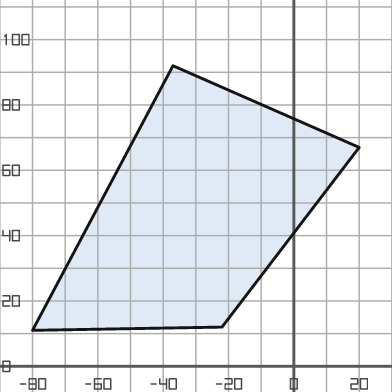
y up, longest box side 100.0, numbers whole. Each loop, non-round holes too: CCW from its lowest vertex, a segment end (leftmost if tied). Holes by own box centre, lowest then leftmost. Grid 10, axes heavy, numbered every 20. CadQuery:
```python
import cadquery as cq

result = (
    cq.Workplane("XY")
    .moveTo(-80.0, 11.0)
    .lineTo(-22.0, 12.0)
    .lineTo(20.0, 67.0)
    .lineTo(-37.0, 92.0)
    .close()
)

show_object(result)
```